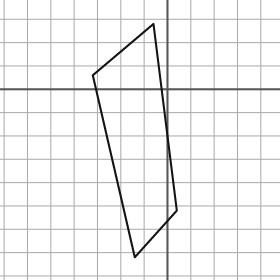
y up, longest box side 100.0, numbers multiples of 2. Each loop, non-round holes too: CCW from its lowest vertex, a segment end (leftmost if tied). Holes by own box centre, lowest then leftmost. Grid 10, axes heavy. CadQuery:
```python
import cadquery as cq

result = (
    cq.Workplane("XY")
    .moveTo(-14.0, -72.0)
    .lineTo(4.0, -52.0)
    .lineTo(-6.0, 28.0)
    .lineTo(-32.0, 6.0)
    .close()
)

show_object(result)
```